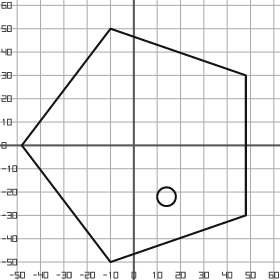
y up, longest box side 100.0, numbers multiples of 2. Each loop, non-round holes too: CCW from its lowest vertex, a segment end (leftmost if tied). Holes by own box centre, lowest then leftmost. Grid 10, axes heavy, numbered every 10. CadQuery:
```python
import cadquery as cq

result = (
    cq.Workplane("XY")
    .moveTo(-10.0, -50.0)
    .lineTo(48.0, -30.0)
    .lineTo(48.0, 30.0)
    .lineTo(-10.0, 50.0)
    .lineTo(-48.0, 0.0)
    .close()
    .moveTo(14.0, -22.0)
    .circle(4.0)
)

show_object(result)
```